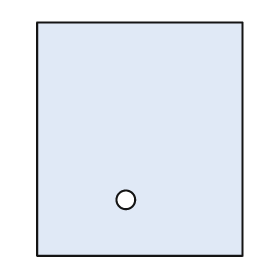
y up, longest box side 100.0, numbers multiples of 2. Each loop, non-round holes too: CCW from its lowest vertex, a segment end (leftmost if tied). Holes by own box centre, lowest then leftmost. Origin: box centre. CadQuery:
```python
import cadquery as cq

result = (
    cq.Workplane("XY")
    .moveTo(-44.0, -50.0)
    .lineTo(44.0, -50.0)
    .lineTo(44.0, 50.0)
    .lineTo(-44.0, 50.0)
    .close()
    .moveTo(-6.0, -26.0)
    .circle(4.0)
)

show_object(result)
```